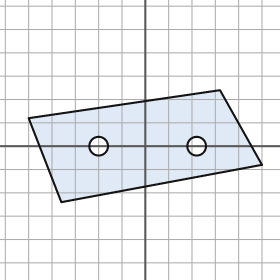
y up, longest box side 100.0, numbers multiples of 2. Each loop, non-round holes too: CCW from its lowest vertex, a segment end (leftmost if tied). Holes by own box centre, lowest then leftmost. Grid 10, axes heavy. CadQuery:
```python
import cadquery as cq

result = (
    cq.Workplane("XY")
    .moveTo(-36.0, -24.0)
    .lineTo(50.0, -8.0)
    .lineTo(32.0, 24.0)
    .lineTo(-50.0, 12.0)
    .close()
    .moveTo(-20.0, 0.0)
    .circle(4.0)
    .moveTo(22.0, 0.0)
    .circle(4.0)
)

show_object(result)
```